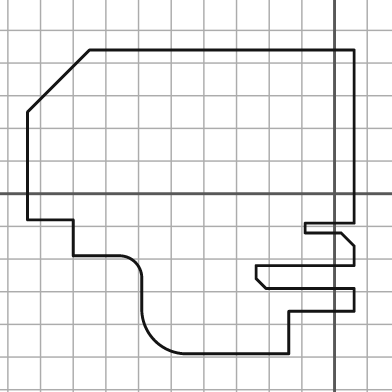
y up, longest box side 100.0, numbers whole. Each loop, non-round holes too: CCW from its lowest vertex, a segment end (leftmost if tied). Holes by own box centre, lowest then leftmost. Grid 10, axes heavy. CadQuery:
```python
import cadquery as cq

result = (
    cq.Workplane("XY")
    .moveTo(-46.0, -49.0)
    .lineTo(-14.0, -49.0)
    .lineTo(-14.0, -36.0)
    .lineTo(6.0, -36.0)
    .lineTo(6.0, -29.0)
    .lineTo(-21.0, -29.0)
    .lineTo(-24.0, -26.0)
    .lineTo(-24.0, -22.0)
    .lineTo(6.0, -22.0)
    .lineTo(6.0, -16.0)
    .lineTo(2.0, -12.0)
    .lineTo(-9.0, -12.0)
    .lineTo(-9.0, -9.0)
    .lineTo(6.0, -9.0)
    .lineTo(6.0, 44.0)
    .lineTo(-75.0, 44.0)
    .lineTo(-94.0, 25.0)
    .lineTo(-94.0, -8.0)
    .lineTo(-80.0, -8.0)
    .lineTo(-80.0, -19.0)
    .lineTo(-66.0, -19.0)
    .threePointArc((-61.0, -21.0), (-59.0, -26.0))
    .lineTo(-59.0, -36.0)
    .threePointArc((-55.0, -45.0), (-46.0, -49.0))
    .close()
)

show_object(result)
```